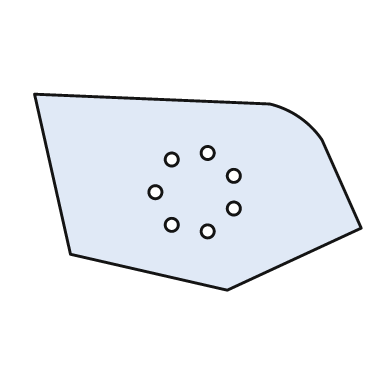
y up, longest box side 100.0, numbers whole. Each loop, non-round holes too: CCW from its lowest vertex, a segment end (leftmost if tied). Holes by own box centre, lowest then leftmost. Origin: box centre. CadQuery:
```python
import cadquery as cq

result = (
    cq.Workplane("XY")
    .moveTo(9.0, -30.0)
    .lineTo(50.0, -11.0)
    .lineTo(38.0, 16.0)
    .threePointArc((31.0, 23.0), (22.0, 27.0))
    .lineTo(-50.0, 30.0)
    .lineTo(-39.0, -19.0)
    .close()
    .moveTo(3.0, -12.0)
    .circle(2.0)
    .moveTo(-8.0, -10.0)
    .circle(2.0)
    .moveTo(11.0, -5.0)
    .circle(2.0)
    .moveTo(-13.0, 0.0)
    .circle(2.0)
    .moveTo(11.0, 5.0)
    .circle(2.0)
    .moveTo(-8.0, 10.0)
    .circle(2.0)
    .moveTo(3.0, 12.0)
    .circle(2.0)
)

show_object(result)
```